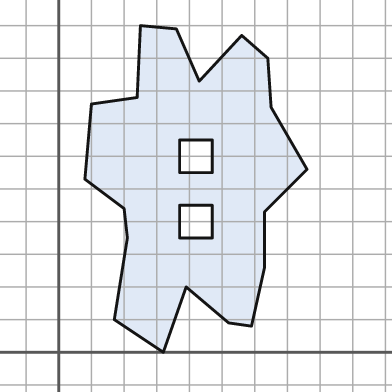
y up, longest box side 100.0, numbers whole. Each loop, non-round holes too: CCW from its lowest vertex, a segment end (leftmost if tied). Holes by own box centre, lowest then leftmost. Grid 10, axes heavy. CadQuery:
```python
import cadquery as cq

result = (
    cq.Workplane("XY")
    .moveTo(32.0, 0.0)
    .lineTo(39.0, 20.0)
    .lineTo(52.0, 9.0)
    .lineTo(59.0, 8.0)
    .lineTo(63.0, 26.0)
    .lineTo(63.0, 43.0)
    .lineTo(76.0, 56.0)
    .lineTo(65.0, 75.0)
    .lineTo(64.0, 90.0)
    .lineTo(56.0, 97.0)
    .lineTo(43.0, 83.0)
    .lineTo(36.0, 99.0)
    .lineTo(25.0, 100.0)
    .lineTo(24.0, 78.0)
    .lineTo(10.0, 76.0)
    .lineTo(8.0, 53.0)
    .lineTo(20.0, 44.0)
    .lineTo(21.0, 35.0)
    .lineTo(17.0, 10.0)
    .close()
    .moveTo(37.0, 35.0)
    .lineTo(47.0, 35.0)
    .lineTo(47.0, 45.0)
    .lineTo(37.0, 45.0)
    .close()
    .moveTo(37.0, 55.0)
    .lineTo(47.0, 55.0)
    .lineTo(47.0, 65.0)
    .lineTo(37.0, 65.0)
    .close()
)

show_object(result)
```